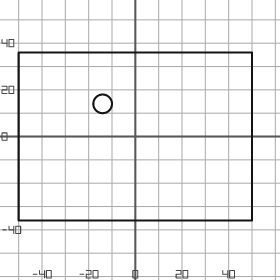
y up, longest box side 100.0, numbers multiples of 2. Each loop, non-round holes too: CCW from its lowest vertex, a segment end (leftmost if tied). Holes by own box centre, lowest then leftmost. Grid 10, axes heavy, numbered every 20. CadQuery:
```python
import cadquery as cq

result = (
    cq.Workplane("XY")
    .moveTo(-50.0, -36.0)
    .lineTo(50.0, -36.0)
    .lineTo(50.0, 36.0)
    .lineTo(-50.0, 36.0)
    .close()
    .moveTo(-14.0, 14.0)
    .circle(4.0)
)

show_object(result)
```